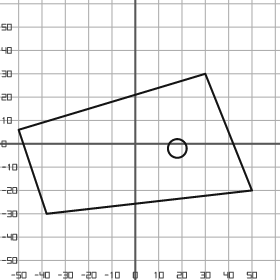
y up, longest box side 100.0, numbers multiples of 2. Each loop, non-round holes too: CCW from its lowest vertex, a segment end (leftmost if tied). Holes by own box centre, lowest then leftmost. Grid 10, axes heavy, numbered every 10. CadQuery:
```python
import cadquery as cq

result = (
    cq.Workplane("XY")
    .moveTo(-38.0, -30.0)
    .lineTo(50.0, -20.0)
    .lineTo(30.0, 30.0)
    .lineTo(-50.0, 6.0)
    .close()
    .moveTo(18.0, -2.0)
    .circle(4.0)
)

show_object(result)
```